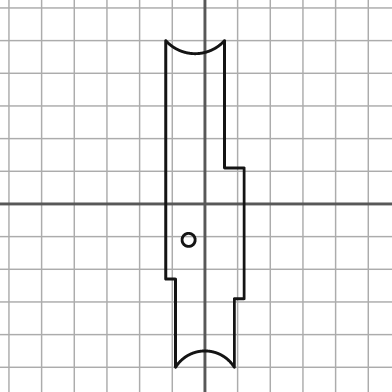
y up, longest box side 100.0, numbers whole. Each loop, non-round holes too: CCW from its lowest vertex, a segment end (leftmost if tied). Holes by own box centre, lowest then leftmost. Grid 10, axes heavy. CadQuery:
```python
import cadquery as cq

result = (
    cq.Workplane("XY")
    .moveTo(-9.0, -50.0)
    .threePointArc((0.0, -45.0), (9.0, -50.0))
    .lineTo(9.0, -29.0)
    .lineTo(12.0, -29.0)
    .lineTo(12.0, 11.0)
    .lineTo(6.0, 11.0)
    .lineTo(6.0, 50.0)
    .threePointArc((-3.0, 46.0), (-12.0, 50.0))
    .lineTo(-12.0, -23.0)
    .lineTo(-9.0, -23.0)
    .close()
    .moveTo(-5.0, -11.0)
    .circle(2.0)
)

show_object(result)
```